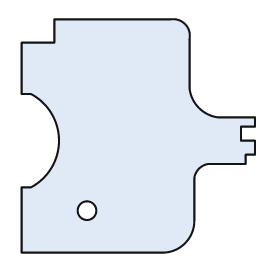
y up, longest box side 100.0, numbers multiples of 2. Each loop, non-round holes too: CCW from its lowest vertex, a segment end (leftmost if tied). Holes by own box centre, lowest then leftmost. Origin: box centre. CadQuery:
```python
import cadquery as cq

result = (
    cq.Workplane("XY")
    .moveTo(-50.0, -50.0)
    .lineTo(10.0, -50.0)
    .threePointArc((20.0, -46.0), (24.0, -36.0))
    .lineTo(24.0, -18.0)
    .threePointArc((26.0, -14.0), (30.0, -12.0))
    .lineTo(46.0, -12.0)
    .lineTo(46.0, -8.0)
    .lineTo(50.0, -8.0)
    .lineTo(50.0, -2.0)
    .lineTo(44.0, -2.0)
    .lineTo(44.0, 4.0)
    .lineTo(50.0, 4.0)
    .lineTo(50.0, 8.0)
    .lineTo(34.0, 8.0)
    .threePointArc((26.0, 12.0), (22.0, 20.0))
    .lineTo(22.0, 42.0)
    .threePointArc((20.0, 48.0), (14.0, 50.0))
    .lineTo(-36.0, 50.0)
    .lineTo(-36.0, 40.0)
    .lineTo(-50.0, 40.0)
    .lineTo(-50.0, 18.0)
    .lineTo(-46.0, 18.0)
    .threePointArc((-34.0, -2.0), (-46.0, -22.0))
    .lineTo(-50.0, -22.0)
    .close()
    .moveTo(-22.0, -32.0)
    .circle(4.0)
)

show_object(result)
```